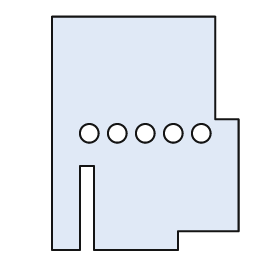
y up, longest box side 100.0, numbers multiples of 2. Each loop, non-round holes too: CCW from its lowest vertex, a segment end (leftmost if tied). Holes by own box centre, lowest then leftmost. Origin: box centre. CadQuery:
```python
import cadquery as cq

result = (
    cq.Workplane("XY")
    .moveTo(-40.0, -50.0)
    .lineTo(-28.0, -50.0)
    .lineTo(-28.0, -14.0)
    .lineTo(-22.0, -14.0)
    .lineTo(-22.0, -50.0)
    .lineTo(14.0, -50.0)
    .lineTo(14.0, -42.0)
    .lineTo(40.0, -42.0)
    .lineTo(40.0, 6.0)
    .lineTo(30.0, 6.0)
    .lineTo(30.0, 50.0)
    .lineTo(-40.0, 50.0)
    .close()
    .moveTo(-24.0, 0.0)
    .circle(4.0)
    .moveTo(-12.0, 0.0)
    .circle(4.0)
    .moveTo(0.0, 0.0)
    .circle(4.0)
    .moveTo(12.0, 0.0)
    .circle(4.0)
    .moveTo(24.0, 0.0)
    .circle(4.0)
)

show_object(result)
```